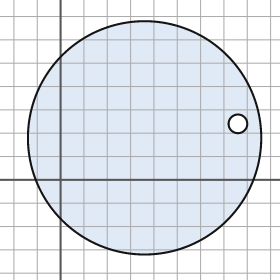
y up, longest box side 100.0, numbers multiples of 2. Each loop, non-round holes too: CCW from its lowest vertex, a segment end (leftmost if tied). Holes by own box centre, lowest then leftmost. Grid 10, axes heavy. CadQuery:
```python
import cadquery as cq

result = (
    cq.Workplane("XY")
    .moveTo(36.0, 18.0)
    .circle(50.0)
    .moveTo(76.0, 24.0)
    .circle(4.0)
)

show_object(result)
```